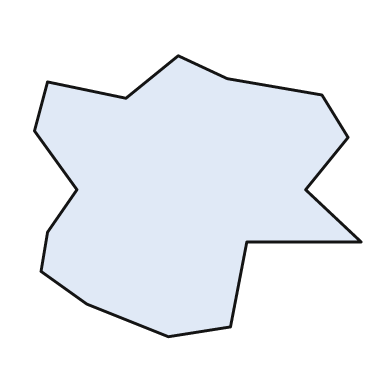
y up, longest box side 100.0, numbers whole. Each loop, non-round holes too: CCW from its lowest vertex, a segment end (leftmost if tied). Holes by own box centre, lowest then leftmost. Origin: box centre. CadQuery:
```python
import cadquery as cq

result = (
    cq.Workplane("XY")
    .moveTo(-9.0, -43.0)
    .lineTo(10.0, -40.0)
    .lineTo(15.0, -14.0)
    .lineTo(50.0, -14.0)
    .lineTo(33.0, 2.0)
    .lineTo(46.0, 18.0)
    .lineTo(38.0, 31.0)
    .lineTo(9.0, 36.0)
    .lineTo(-6.0, 43.0)
    .lineTo(-22.0, 30.0)
    .lineTo(-46.0, 35.0)
    .lineTo(-50.0, 20.0)
    .lineTo(-37.0, 2.0)
    .lineTo(-46.0, -11.0)
    .lineTo(-48.0, -23.0)
    .lineTo(-34.0, -33.0)
    .close()
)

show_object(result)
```